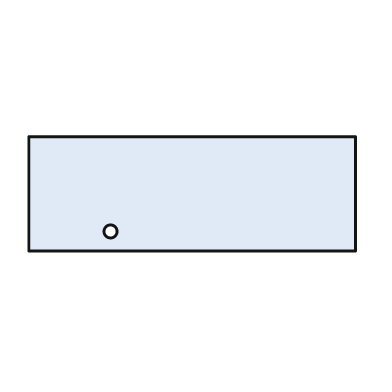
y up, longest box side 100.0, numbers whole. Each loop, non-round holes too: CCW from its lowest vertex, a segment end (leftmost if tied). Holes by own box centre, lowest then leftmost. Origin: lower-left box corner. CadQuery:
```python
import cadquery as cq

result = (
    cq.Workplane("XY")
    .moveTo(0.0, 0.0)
    .lineTo(100.0, 0.0)
    .lineTo(100.0, 35.0)
    .lineTo(0.0, 35.0)
    .close()
    .moveTo(25.0, 6.0)
    .circle(2.0)
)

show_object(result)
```